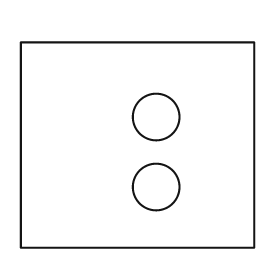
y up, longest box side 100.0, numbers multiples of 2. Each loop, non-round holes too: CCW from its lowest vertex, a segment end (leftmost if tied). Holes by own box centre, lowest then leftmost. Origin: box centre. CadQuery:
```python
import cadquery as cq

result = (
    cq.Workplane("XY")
    .moveTo(-50.0, -44.0)
    .lineTo(50.0, -44.0)
    .lineTo(50.0, 44.0)
    .lineTo(-50.0, 44.0)
    .close()
    .moveTo(8.0, -18.0)
    .circle(10.0)
    .moveTo(8.0, 12.0)
    .circle(10.0)
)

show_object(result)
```